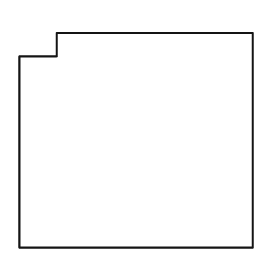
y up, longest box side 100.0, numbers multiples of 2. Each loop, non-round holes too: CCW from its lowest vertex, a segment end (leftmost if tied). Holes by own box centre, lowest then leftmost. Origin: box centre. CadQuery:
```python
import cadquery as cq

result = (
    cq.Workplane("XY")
    .moveTo(-50.0, -46.0)
    .lineTo(50.0, -46.0)
    .lineTo(50.0, 46.0)
    .lineTo(-34.0, 46.0)
    .lineTo(-34.0, 36.0)
    .lineTo(-50.0, 36.0)
    .close()
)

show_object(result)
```